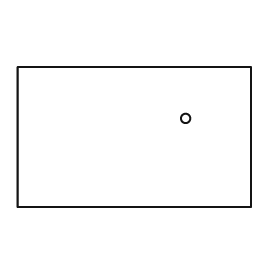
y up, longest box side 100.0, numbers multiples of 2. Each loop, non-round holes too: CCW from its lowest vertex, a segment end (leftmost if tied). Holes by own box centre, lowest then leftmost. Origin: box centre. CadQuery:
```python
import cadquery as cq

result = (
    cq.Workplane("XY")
    .moveTo(-50.0, -30.0)
    .lineTo(50.0, -30.0)
    .lineTo(50.0, 30.0)
    .lineTo(-50.0, 30.0)
    .close()
    .moveTo(22.0, 8.0)
    .circle(2.0)
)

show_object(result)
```